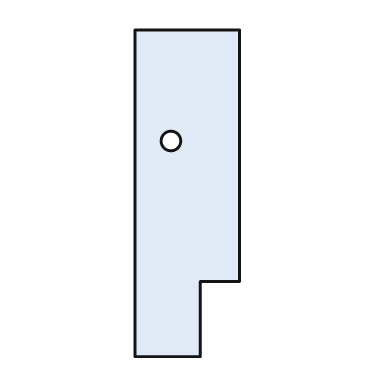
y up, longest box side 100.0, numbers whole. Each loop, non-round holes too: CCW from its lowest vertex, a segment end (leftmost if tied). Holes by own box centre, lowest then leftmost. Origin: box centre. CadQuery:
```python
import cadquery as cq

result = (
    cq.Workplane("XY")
    .moveTo(-16.0, -50.0)
    .lineTo(4.0, -50.0)
    .lineTo(4.0, -27.0)
    .lineTo(16.0, -27.0)
    .lineTo(16.0, 50.0)
    .lineTo(-16.0, 50.0)
    .close()
    .moveTo(-5.0, 16.0)
    .circle(3.0)
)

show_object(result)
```